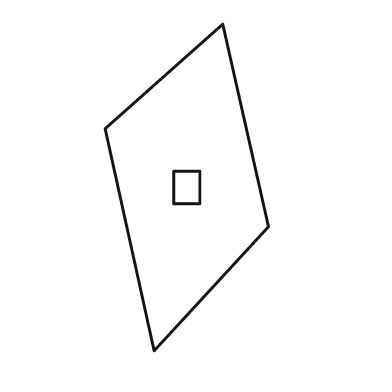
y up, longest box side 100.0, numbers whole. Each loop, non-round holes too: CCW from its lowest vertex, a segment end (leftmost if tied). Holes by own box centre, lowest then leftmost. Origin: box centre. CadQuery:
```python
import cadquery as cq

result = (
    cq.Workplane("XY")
    .moveTo(-10.0, -50.0)
    .lineTo(25.0, -12.0)
    .lineTo(11.0, 50.0)
    .lineTo(-25.0, 18.0)
    .close()
    .moveTo(-4.0, -5.0)
    .lineTo(4.0, -5.0)
    .lineTo(4.0, 5.0)
    .lineTo(-4.0, 5.0)
    .close()
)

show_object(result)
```